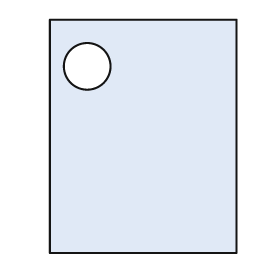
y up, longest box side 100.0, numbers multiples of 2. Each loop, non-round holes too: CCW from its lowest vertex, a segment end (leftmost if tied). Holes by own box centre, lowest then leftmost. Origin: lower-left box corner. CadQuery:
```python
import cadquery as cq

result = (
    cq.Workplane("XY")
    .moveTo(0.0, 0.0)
    .lineTo(80.0, 0.0)
    .lineTo(80.0, 100.0)
    .lineTo(0.0, 100.0)
    .close()
    .moveTo(16.0, 80.0)
    .circle(10.0)
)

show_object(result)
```